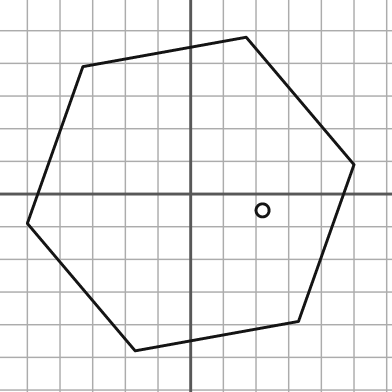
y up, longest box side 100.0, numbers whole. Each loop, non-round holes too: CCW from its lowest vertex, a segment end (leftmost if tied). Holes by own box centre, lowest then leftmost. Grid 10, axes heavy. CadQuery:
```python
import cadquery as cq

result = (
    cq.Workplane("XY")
    .moveTo(-17.0, -48.0)
    .lineTo(33.0, -39.0)
    .lineTo(50.0, 9.0)
    .lineTo(17.0, 48.0)
    .lineTo(-33.0, 39.0)
    .lineTo(-50.0, -9.0)
    .close()
    .moveTo(22.0, -5.0)
    .circle(2.0)
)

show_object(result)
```